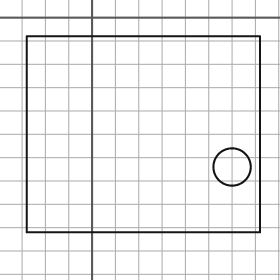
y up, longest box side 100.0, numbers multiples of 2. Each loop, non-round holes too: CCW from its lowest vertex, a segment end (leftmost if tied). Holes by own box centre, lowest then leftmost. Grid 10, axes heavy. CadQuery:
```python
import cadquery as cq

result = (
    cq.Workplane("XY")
    .moveTo(-28.0, -92.0)
    .lineTo(72.0, -92.0)
    .lineTo(72.0, -8.0)
    .lineTo(-28.0, -8.0)
    .close()
    .moveTo(60.0, -64.0)
    .circle(8.0)
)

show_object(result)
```